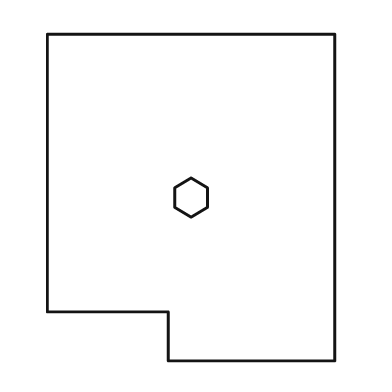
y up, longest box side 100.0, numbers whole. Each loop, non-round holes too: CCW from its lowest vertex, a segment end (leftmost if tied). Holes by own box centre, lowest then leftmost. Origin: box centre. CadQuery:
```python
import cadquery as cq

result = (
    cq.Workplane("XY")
    .moveTo(-7.0, -50.0)
    .lineTo(44.0, -50.0)
    .lineTo(44.0, 50.0)
    .lineTo(-44.0, 50.0)
    .lineTo(-44.0, -35.0)
    .lineTo(-7.0, -35.0)
    .close()
    .moveTo(0.0, -6.0)
    .lineTo(5.0, -3.0)
    .lineTo(5.0, 3.0)
    .lineTo(0.0, 6.0)
    .lineTo(-5.0, 3.0)
    .lineTo(-5.0, -3.0)
    .close()
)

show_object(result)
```